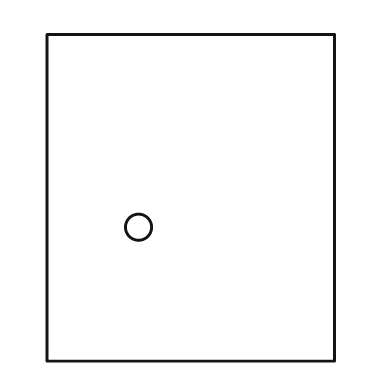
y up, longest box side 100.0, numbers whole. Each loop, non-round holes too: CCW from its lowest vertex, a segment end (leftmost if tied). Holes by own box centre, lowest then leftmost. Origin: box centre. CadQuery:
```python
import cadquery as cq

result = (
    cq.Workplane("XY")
    .moveTo(-44.0, -50.0)
    .lineTo(44.0, -50.0)
    .lineTo(44.0, 50.0)
    .lineTo(-44.0, 50.0)
    .close()
    .moveTo(-16.0, -9.0)
    .circle(4.0)
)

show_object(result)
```